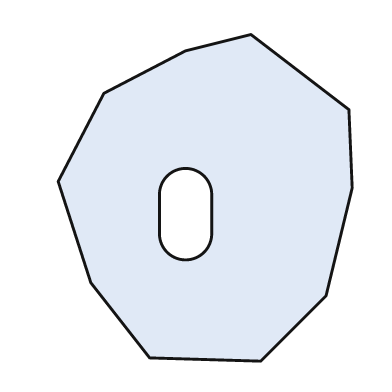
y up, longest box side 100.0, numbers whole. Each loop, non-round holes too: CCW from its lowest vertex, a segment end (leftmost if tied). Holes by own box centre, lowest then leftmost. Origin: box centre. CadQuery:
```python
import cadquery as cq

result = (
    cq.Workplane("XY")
    .moveTo(17.0, -50.0)
    .lineTo(37.0, -30.0)
    .lineTo(45.0, 3.0)
    .lineTo(44.0, 27.0)
    .lineTo(14.0, 50.0)
    .lineTo(-6.0, 45.0)
    .lineTo(-31.0, 32.0)
    .lineTo(-45.0, 5.0)
    .lineTo(-35.0, -26.0)
    .lineTo(-17.0, -49.0)
    .close()
    .moveTo(-14.0, -11.0)
    .threePointArc((-6.0, -19.0), (2.0, -11.0))
    .lineTo(2.0, 1.0)
    .threePointArc((-6.0, 9.0), (-14.0, 1.0))
    .close()
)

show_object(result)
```